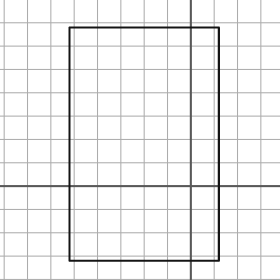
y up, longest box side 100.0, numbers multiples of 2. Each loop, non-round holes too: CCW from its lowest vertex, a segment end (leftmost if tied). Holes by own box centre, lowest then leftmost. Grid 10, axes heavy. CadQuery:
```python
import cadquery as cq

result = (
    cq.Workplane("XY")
    .moveTo(-52.0, -32.0)
    .lineTo(12.0, -32.0)
    .lineTo(12.0, 68.0)
    .lineTo(-52.0, 68.0)
    .close()
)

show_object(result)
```